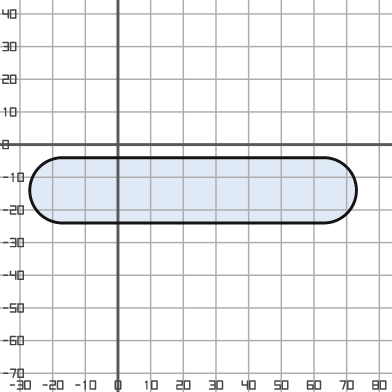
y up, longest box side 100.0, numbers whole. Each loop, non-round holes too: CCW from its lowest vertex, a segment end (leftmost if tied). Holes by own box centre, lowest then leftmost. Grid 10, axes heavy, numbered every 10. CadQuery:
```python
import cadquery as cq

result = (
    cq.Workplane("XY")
    .moveTo(-17.0, -24.0)
    .lineTo(63.0, -24.0)
    .threePointArc((73.0, -14.0), (63.0, -4.0))
    .lineTo(-17.0, -4.0)
    .threePointArc((-27.0, -14.0), (-17.0, -24.0))
    .close()
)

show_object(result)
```